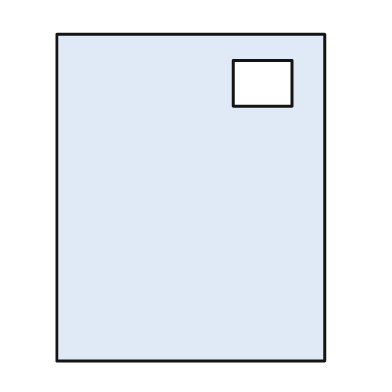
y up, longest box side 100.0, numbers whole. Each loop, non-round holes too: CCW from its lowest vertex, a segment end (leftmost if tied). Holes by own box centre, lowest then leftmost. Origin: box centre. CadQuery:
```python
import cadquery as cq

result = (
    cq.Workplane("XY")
    .moveTo(-41.0, -50.0)
    .lineTo(41.0, -50.0)
    .lineTo(41.0, 50.0)
    .lineTo(-41.0, 50.0)
    .close()
    .moveTo(13.0, 28.0)
    .lineTo(31.0, 28.0)
    .lineTo(31.0, 42.0)
    .lineTo(13.0, 42.0)
    .close()
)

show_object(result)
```